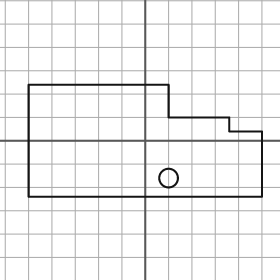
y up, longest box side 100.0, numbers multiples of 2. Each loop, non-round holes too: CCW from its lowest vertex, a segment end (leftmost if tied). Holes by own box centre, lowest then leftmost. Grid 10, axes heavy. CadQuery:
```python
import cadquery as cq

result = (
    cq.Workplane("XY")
    .moveTo(-50.0, -24.0)
    .lineTo(50.0, -24.0)
    .lineTo(50.0, 4.0)
    .lineTo(36.0, 4.0)
    .lineTo(36.0, 10.0)
    .lineTo(10.0, 10.0)
    .lineTo(10.0, 24.0)
    .lineTo(-50.0, 24.0)
    .close()
    .moveTo(10.0, -16.0)
    .circle(4.0)
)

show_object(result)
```